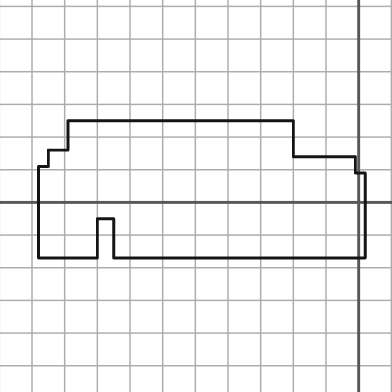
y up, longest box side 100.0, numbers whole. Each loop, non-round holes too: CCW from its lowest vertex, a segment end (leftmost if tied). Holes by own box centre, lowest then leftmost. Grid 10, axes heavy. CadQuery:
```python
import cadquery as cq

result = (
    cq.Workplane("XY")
    .moveTo(-98.0, -17.0)
    .lineTo(-80.0, -17.0)
    .lineTo(-80.0, -5.0)
    .lineTo(-75.0, -5.0)
    .lineTo(-75.0, -17.0)
    .lineTo(2.0, -17.0)
    .lineTo(2.0, 9.0)
    .lineTo(-1.0, 9.0)
    .lineTo(-1.0, 14.0)
    .lineTo(-20.0, 14.0)
    .lineTo(-20.0, 25.0)
    .lineTo(-89.0, 25.0)
    .lineTo(-89.0, 16.0)
    .lineTo(-95.0, 16.0)
    .lineTo(-95.0, 11.0)
    .lineTo(-98.0, 11.0)
    .close()
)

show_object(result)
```